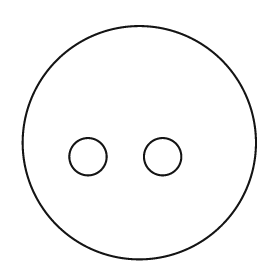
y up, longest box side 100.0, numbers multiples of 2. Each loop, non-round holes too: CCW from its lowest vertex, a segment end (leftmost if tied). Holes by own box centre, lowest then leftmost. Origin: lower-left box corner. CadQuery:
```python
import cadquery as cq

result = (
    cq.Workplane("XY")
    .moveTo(50.0, 50.0)
    .circle(50.0)
    .moveTo(28.0, 44.0)
    .circle(8.0)
    .moveTo(60.0, 44.0)
    .circle(8.0)
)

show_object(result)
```